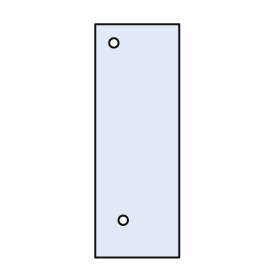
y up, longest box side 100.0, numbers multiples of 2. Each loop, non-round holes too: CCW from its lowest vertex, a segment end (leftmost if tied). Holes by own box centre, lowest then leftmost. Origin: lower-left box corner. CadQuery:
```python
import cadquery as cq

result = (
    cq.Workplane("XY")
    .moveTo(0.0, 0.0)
    .lineTo(36.0, 0.0)
    .lineTo(36.0, 100.0)
    .lineTo(0.0, 100.0)
    .close()
    .moveTo(12.0, 16.0)
    .circle(2.0)
    .moveTo(8.0, 92.0)
    .circle(2.0)
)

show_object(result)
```